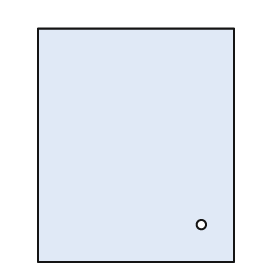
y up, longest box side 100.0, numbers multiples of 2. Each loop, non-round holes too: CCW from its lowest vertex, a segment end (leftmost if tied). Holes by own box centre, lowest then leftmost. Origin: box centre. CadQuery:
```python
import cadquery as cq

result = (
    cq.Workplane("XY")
    .moveTo(-42.0, -50.0)
    .lineTo(42.0, -50.0)
    .lineTo(42.0, 50.0)
    .lineTo(-42.0, 50.0)
    .close()
    .moveTo(28.0, -34.0)
    .circle(2.0)
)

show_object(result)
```